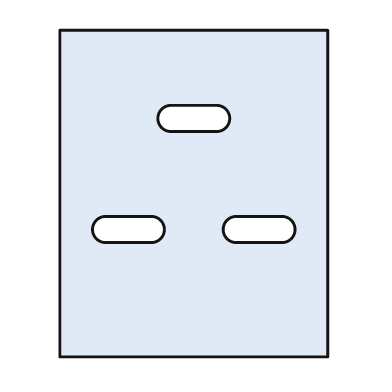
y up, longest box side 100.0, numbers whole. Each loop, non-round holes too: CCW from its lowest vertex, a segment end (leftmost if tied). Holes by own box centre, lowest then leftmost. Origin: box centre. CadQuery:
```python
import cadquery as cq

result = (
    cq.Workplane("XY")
    .moveTo(-41.0, -50.0)
    .lineTo(41.0, -50.0)
    .lineTo(41.0, 50.0)
    .lineTo(-41.0, 50.0)
    .close()
    .moveTo(-27.0, -15.0)
    .lineTo(-13.0, -15.0)
    .threePointArc((-9.0, -11.0), (-13.0, -7.0))
    .lineTo(-27.0, -7.0)
    .threePointArc((-31.0, -11.0), (-27.0, -15.0))
    .close()
    .moveTo(13.0, -15.0)
    .lineTo(27.0, -15.0)
    .threePointArc((31.0, -11.0), (27.0, -7.0))
    .lineTo(13.0, -7.0)
    .threePointArc((9.0, -11.0), (13.0, -15.0))
    .close()
    .moveTo(-7.0, 19.0)
    .lineTo(7.0, 19.0)
    .threePointArc((11.0, 23.0), (7.0, 27.0))
    .lineTo(-7.0, 27.0)
    .threePointArc((-11.0, 23.0), (-7.0, 19.0))
    .close()
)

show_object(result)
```